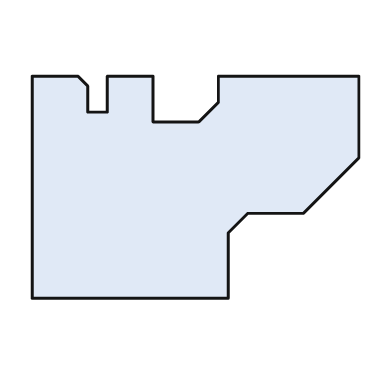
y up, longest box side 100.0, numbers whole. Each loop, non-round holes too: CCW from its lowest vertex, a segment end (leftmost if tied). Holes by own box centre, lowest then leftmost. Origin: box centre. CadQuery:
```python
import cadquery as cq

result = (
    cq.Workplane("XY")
    .moveTo(-50.0, -34.0)
    .lineTo(10.0, -34.0)
    .lineTo(10.0, -14.0)
    .lineTo(16.0, -8.0)
    .lineTo(33.0, -8.0)
    .lineTo(50.0, 9.0)
    .lineTo(50.0, 34.0)
    .lineTo(7.0, 34.0)
    .lineTo(7.0, 26.0)
    .lineTo(1.0, 20.0)
    .lineTo(-13.0, 20.0)
    .lineTo(-13.0, 34.0)
    .lineTo(-27.0, 34.0)
    .lineTo(-27.0, 23.0)
    .lineTo(-33.0, 23.0)
    .lineTo(-33.0, 31.0)
    .lineTo(-36.0, 34.0)
    .lineTo(-50.0, 34.0)
    .close()
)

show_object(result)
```